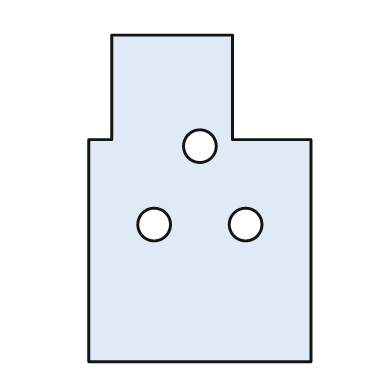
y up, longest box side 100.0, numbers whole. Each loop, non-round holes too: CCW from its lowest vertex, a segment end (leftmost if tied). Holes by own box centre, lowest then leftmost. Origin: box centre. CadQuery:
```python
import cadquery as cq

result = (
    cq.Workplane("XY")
    .moveTo(-34.0, -50.0)
    .lineTo(34.0, -50.0)
    .lineTo(34.0, 18.0)
    .lineTo(10.0, 18.0)
    .lineTo(10.0, 50.0)
    .lineTo(-27.0, 50.0)
    .lineTo(-27.0, 18.0)
    .lineTo(-34.0, 18.0)
    .close()
    .moveTo(-14.0, -8.0)
    .circle(5.0)
    .moveTo(14.0, -8.0)
    .circle(5.0)
    .moveTo(0.0, 16.0)
    .circle(5.0)
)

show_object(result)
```